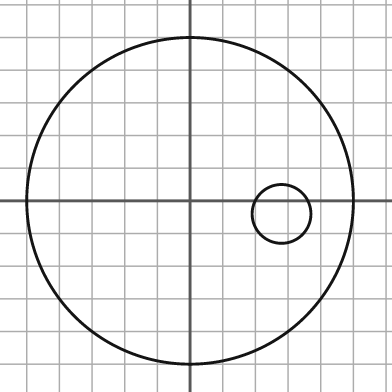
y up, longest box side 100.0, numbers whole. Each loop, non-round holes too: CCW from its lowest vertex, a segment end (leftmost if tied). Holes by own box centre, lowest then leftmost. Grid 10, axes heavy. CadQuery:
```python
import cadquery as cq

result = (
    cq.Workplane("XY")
    .moveTo(0.0, 0.0)
    .circle(50.0)
    .moveTo(28.0, -4.0)
    .circle(9.0)
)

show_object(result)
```